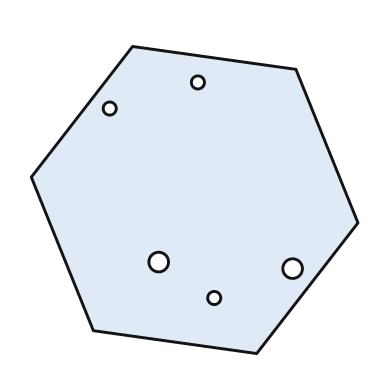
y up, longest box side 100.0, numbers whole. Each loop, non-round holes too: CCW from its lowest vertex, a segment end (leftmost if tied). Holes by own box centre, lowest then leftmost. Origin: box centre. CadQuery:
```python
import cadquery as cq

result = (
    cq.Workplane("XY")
    .moveTo(19.0, -47.0)
    .lineTo(50.0, -7.0)
    .lineTo(31.0, 40.0)
    .lineTo(-19.0, 47.0)
    .lineTo(-50.0, 7.0)
    .lineTo(-31.0, -40.0)
    .close()
    .moveTo(6.0, -30.0)
    .circle(2.0)
    .moveTo(30.0, -21.0)
    .circle(3.0)
    .moveTo(-11.0, -19.0)
    .circle(3.0)
    .moveTo(-26.0, 28.0)
    .circle(2.0)
    .moveTo(1.0, 36.0)
    .circle(2.0)
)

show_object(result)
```